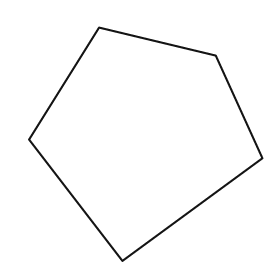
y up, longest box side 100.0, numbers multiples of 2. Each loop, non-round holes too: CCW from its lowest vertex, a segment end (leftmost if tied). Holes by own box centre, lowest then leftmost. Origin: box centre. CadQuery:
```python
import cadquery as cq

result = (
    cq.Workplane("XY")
    .moveTo(-10.0, -50.0)
    .lineTo(50.0, -6.0)
    .lineTo(30.0, 38.0)
    .lineTo(-20.0, 50.0)
    .lineTo(-50.0, 2.0)
    .close()
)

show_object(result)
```